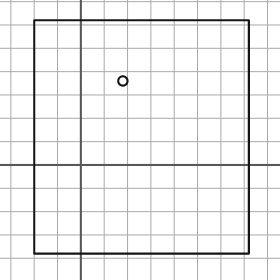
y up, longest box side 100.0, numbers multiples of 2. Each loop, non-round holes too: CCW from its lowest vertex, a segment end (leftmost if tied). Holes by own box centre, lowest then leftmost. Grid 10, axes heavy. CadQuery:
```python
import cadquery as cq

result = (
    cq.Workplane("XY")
    .moveTo(-20.0, -38.0)
    .lineTo(72.0, -38.0)
    .lineTo(72.0, 62.0)
    .lineTo(-20.0, 62.0)
    .close()
    .moveTo(18.0, 36.0)
    .circle(2.0)
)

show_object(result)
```